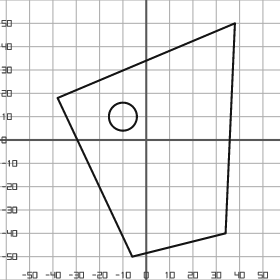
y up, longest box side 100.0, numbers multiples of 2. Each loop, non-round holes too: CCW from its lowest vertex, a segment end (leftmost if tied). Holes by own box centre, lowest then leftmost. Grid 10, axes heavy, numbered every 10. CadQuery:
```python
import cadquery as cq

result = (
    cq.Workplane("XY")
    .moveTo(-6.0, -50.0)
    .lineTo(34.0, -40.0)
    .lineTo(38.0, 50.0)
    .lineTo(-38.0, 18.0)
    .close()
    .moveTo(-10.0, 10.0)
    .circle(6.0)
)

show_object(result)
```